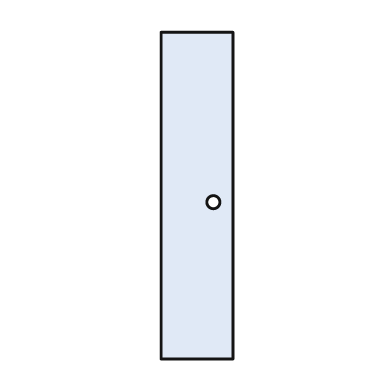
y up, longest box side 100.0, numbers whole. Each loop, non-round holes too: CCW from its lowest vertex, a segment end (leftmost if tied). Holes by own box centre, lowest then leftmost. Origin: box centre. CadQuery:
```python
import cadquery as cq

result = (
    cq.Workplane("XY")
    .moveTo(-11.0, -50.0)
    .lineTo(11.0, -50.0)
    .lineTo(11.0, 50.0)
    .lineTo(-11.0, 50.0)
    .close()
    .moveTo(5.0, -2.0)
    .circle(2.0)
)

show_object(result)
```